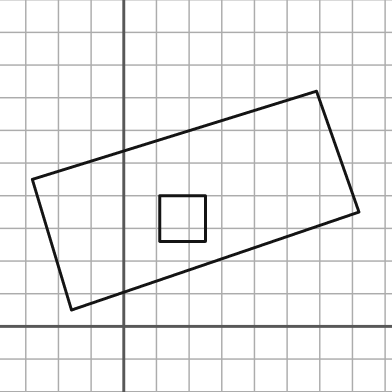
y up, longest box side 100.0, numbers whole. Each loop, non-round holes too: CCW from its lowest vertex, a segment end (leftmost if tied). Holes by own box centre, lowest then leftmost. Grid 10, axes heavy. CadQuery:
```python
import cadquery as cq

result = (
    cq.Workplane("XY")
    .moveTo(-16.0, 5.0)
    .lineTo(72.0, 35.0)
    .lineTo(59.0, 72.0)
    .lineTo(-28.0, 45.0)
    .close()
    .moveTo(11.0, 26.0)
    .lineTo(25.0, 26.0)
    .lineTo(25.0, 40.0)
    .lineTo(11.0, 40.0)
    .close()
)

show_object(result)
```